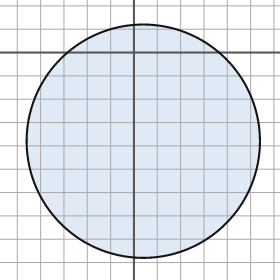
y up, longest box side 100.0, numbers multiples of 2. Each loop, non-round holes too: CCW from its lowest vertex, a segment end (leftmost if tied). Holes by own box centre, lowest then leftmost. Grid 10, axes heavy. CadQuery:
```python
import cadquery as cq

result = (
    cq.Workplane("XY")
    .moveTo(4.0, -38.0)
    .circle(50.0)
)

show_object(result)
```